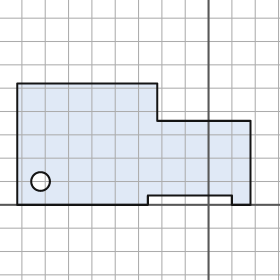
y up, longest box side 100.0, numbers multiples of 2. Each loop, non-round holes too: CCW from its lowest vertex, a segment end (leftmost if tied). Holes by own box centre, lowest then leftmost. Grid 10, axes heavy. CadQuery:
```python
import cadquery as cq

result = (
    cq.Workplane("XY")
    .moveTo(-82.0, 0.0)
    .lineTo(-26.0, 0.0)
    .lineTo(-26.0, 4.0)
    .lineTo(10.0, 4.0)
    .lineTo(10.0, 0.0)
    .lineTo(18.0, 0.0)
    .lineTo(18.0, 36.0)
    .lineTo(-22.0, 36.0)
    .lineTo(-22.0, 52.0)
    .lineTo(-82.0, 52.0)
    .close()
    .moveTo(-72.0, 10.0)
    .circle(4.0)
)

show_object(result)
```